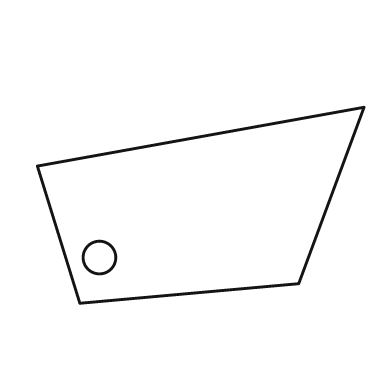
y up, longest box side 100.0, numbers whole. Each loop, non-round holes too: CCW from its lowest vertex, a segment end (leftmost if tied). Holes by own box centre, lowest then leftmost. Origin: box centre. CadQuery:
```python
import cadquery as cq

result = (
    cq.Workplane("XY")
    .moveTo(-37.0, -30.0)
    .lineTo(30.0, -24.0)
    .lineTo(50.0, 30.0)
    .lineTo(-50.0, 12.0)
    .close()
    .moveTo(-31.0, -16.0)
    .circle(5.0)
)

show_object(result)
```